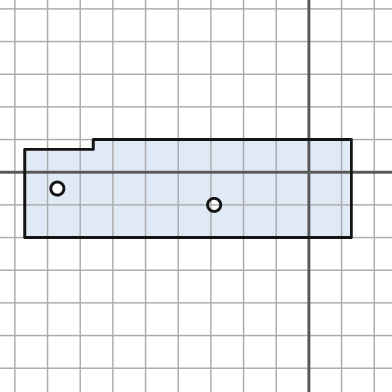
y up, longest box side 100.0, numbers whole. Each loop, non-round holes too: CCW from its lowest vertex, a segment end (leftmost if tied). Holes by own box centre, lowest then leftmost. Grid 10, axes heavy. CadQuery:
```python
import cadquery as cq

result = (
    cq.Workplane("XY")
    .moveTo(-87.0, -20.0)
    .lineTo(13.0, -20.0)
    .lineTo(13.0, 10.0)
    .lineTo(-66.0, 10.0)
    .lineTo(-66.0, 7.0)
    .lineTo(-87.0, 7.0)
    .close()
    .moveTo(-29.0, -10.0)
    .circle(2.0)
    .moveTo(-77.0, -5.0)
    .circle(2.0)
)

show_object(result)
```